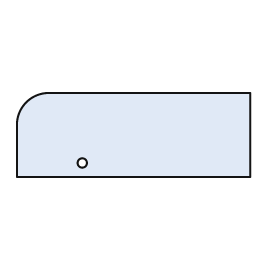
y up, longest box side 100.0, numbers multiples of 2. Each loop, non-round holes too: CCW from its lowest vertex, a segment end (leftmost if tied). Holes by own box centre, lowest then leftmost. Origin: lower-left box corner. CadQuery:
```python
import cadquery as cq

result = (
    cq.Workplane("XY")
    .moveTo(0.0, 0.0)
    .lineTo(100.0, 0.0)
    .lineTo(100.0, 36.0)
    .lineTo(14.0, 36.0)
    .threePointArc((4.0, 32.0), (0.0, 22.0))
    .close()
    .moveTo(28.0, 6.0)
    .circle(2.0)
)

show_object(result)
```